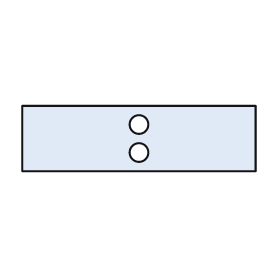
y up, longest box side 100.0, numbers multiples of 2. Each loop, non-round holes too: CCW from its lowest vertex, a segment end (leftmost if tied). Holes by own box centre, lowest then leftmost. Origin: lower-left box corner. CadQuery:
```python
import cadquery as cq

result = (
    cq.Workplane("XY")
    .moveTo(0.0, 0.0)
    .lineTo(100.0, 0.0)
    .lineTo(100.0, 28.0)
    .lineTo(0.0, 28.0)
    .close()
    .moveTo(50.0, 8.0)
    .circle(4.0)
    .moveTo(50.0, 20.0)
    .circle(4.0)
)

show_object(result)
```